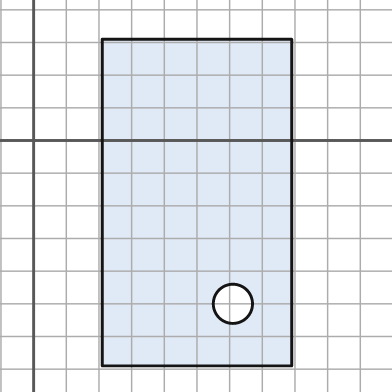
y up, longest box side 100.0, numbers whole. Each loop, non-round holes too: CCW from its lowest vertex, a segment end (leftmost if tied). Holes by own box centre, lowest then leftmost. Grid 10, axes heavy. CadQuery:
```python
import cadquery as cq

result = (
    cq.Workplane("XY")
    .moveTo(21.0, -69.0)
    .lineTo(79.0, -69.0)
    .lineTo(79.0, 31.0)
    .lineTo(21.0, 31.0)
    .close()
    .moveTo(61.0, -50.0)
    .circle(6.0)
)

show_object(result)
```